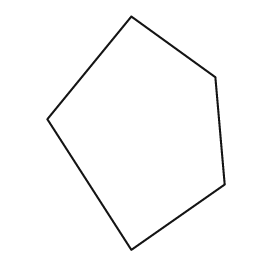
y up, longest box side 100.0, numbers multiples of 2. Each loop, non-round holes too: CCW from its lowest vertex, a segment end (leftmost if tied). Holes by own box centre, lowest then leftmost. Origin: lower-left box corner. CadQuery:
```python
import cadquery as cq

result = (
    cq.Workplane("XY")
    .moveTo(36.0, 0.0)
    .lineTo(76.0, 28.0)
    .lineTo(72.0, 74.0)
    .lineTo(36.0, 100.0)
    .lineTo(0.0, 56.0)
    .close()
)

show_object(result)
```